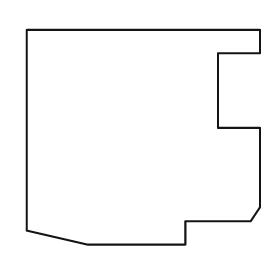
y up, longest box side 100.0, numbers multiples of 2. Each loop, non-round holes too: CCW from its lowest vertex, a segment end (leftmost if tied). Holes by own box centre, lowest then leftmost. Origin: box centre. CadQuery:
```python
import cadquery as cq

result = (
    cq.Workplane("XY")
    .moveTo(-24.0, -46.0)
    .lineTo(18.0, -46.0)
    .lineTo(18.0, -36.0)
    .lineTo(46.0, -36.0)
    .lineTo(50.0, -30.0)
    .lineTo(50.0, 4.0)
    .lineTo(32.0, 4.0)
    .lineTo(32.0, 36.0)
    .lineTo(50.0, 36.0)
    .lineTo(50.0, 46.0)
    .lineTo(-50.0, 46.0)
    .lineTo(-50.0, -40.0)
    .close()
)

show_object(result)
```